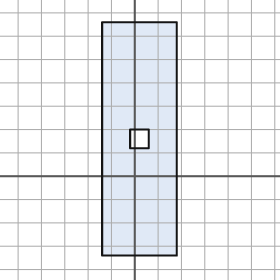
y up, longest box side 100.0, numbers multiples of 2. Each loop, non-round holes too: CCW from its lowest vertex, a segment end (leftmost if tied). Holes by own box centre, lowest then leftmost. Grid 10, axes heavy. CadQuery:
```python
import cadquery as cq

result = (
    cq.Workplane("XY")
    .moveTo(-14.0, -34.0)
    .lineTo(18.0, -34.0)
    .lineTo(18.0, 66.0)
    .lineTo(-14.0, 66.0)
    .close()
    .moveTo(-2.0, 12.0)
    .lineTo(6.0, 12.0)
    .lineTo(6.0, 20.0)
    .lineTo(-2.0, 20.0)
    .close()
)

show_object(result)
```